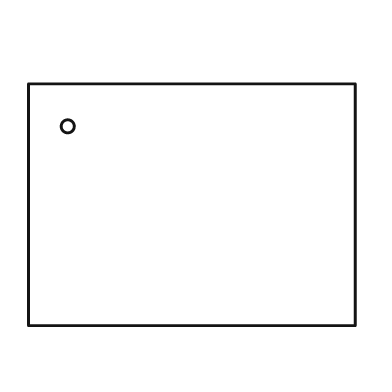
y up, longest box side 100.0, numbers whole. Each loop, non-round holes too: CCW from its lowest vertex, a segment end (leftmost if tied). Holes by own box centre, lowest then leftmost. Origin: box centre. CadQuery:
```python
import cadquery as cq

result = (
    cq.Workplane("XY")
    .moveTo(-50.0, -37.0)
    .lineTo(50.0, -37.0)
    .lineTo(50.0, 37.0)
    .lineTo(-50.0, 37.0)
    .close()
    .moveTo(-38.0, 24.0)
    .circle(2.0)
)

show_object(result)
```